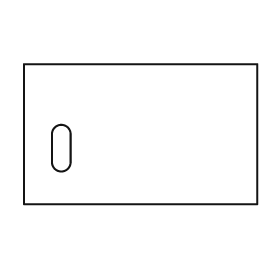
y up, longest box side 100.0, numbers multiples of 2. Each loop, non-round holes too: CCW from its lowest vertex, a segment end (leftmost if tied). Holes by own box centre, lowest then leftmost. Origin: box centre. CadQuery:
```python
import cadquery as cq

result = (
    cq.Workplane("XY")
    .moveTo(-50.0, -30.0)
    .lineTo(50.0, -30.0)
    .lineTo(50.0, 30.0)
    .lineTo(-50.0, 30.0)
    .close()
    .moveTo(-38.0, -12.0)
    .threePointArc((-34.0, -16.0), (-30.0, -12.0))
    .lineTo(-30.0, 0.0)
    .threePointArc((-34.0, 4.0), (-38.0, 0.0))
    .close()
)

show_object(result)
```